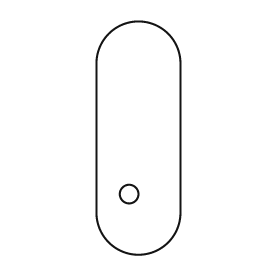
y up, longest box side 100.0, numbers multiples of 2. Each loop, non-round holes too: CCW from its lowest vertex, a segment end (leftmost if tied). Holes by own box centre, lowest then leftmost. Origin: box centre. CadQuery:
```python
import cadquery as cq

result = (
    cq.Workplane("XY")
    .moveTo(-18.0, -32.0)
    .threePointArc((0.0, -50.0), (18.0, -32.0))
    .lineTo(18.0, 32.0)
    .threePointArc((0.0, 50.0), (-18.0, 32.0))
    .close()
    .moveTo(-4.0, -24.0)
    .circle(4.0)
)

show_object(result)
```